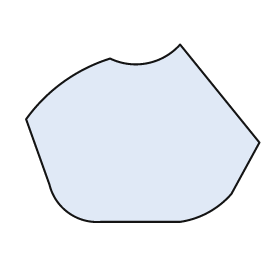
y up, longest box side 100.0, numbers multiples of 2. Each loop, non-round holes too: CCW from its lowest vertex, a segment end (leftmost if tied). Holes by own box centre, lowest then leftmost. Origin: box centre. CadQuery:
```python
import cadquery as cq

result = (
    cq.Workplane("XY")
    .moveTo(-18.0, -38.0)
    .lineTo(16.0, -38.0)
    .threePointArc((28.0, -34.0), (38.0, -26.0))
    .lineTo(50.0, -4.0)
    .lineTo(16.0, 38.0)
    .threePointArc((2.0, 30.0), (-14.0, 32.0))
    .threePointArc((-34.0, 22.0), (-50.0, 6.0))
    .lineTo(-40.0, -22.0)
    .threePointArc((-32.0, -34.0), (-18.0, -38.0))
    .close()
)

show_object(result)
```